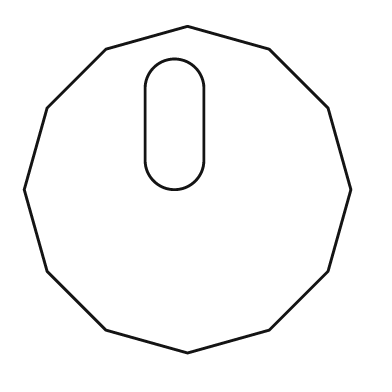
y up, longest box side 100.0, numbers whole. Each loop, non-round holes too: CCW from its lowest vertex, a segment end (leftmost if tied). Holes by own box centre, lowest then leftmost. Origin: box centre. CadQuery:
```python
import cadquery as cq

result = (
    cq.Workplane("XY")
    .moveTo(0.0, -50.0)
    .lineTo(25.0, -43.0)
    .lineTo(43.0, -25.0)
    .lineTo(50.0, 0.0)
    .lineTo(43.0, 25.0)
    .lineTo(25.0, 43.0)
    .lineTo(0.0, 50.0)
    .lineTo(-25.0, 43.0)
    .lineTo(-43.0, 25.0)
    .lineTo(-50.0, 0.0)
    .lineTo(-43.0, -25.0)
    .lineTo(-25.0, -43.0)
    .close()
    .moveTo(-13.0, 9.0)
    .threePointArc((-4.0, 0.0), (5.0, 9.0))
    .lineTo(5.0, 31.0)
    .threePointArc((-4.0, 40.0), (-13.0, 31.0))
    .close()
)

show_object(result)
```